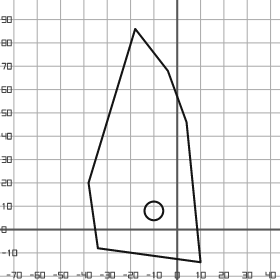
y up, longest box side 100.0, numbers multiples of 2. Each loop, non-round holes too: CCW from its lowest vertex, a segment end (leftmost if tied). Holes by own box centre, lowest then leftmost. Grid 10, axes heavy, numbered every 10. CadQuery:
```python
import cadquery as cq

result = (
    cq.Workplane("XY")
    .moveTo(10.0, -14.0)
    .lineTo(4.0, 46.0)
    .lineTo(-4.0, 68.0)
    .lineTo(-18.0, 86.0)
    .lineTo(-38.0, 20.0)
    .lineTo(-34.0, -8.0)
    .close()
    .moveTo(-10.0, 8.0)
    .circle(4.0)
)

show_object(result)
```